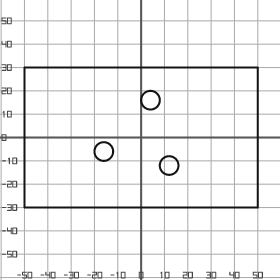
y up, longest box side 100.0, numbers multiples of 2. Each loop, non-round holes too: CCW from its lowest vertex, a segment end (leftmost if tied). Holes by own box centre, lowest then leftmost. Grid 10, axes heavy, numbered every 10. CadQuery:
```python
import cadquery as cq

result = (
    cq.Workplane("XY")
    .moveTo(-50.0, -30.0)
    .lineTo(50.0, -30.0)
    .lineTo(50.0, 30.0)
    .lineTo(-50.0, 30.0)
    .close()
    .moveTo(12.0, -12.0)
    .circle(4.0)
    .moveTo(-16.0, -6.0)
    .circle(4.0)
    .moveTo(4.0, 16.0)
    .circle(4.0)
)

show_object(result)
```